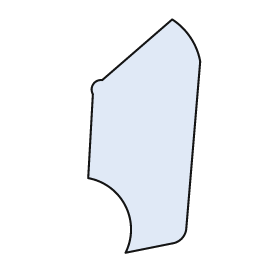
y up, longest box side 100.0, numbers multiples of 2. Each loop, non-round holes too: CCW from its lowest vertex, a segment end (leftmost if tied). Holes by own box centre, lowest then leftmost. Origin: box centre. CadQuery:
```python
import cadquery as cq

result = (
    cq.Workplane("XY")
    .moveTo(-8.0, -50.0)
    .lineTo(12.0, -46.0)
    .threePointArc((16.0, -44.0), (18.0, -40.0))
    .lineTo(24.0, 32.0)
    .threePointArc((20.0, 42.0), (12.0, 50.0))
    .lineTo(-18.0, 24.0)
    .threePointArc((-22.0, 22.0), (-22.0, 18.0))
    .lineTo(-24.0, -18.0)
    .threePointArc((-8.0, -30.0), (-8.0, -50.0))
    .close()
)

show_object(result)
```